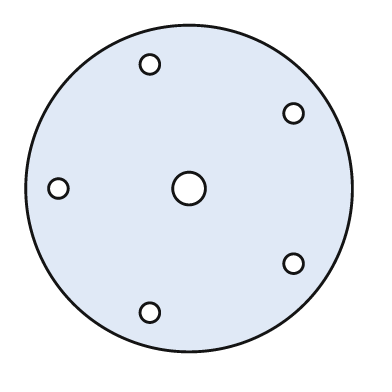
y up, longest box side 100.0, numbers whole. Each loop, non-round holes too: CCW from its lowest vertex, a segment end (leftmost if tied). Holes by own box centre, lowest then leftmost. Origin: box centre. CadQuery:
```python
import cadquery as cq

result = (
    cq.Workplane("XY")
    .moveTo(0.0, 0.0)
    .circle(50.0)
    .moveTo(-12.0, -38.0)
    .circle(3.0)
    .moveTo(32.0, -23.0)
    .circle(3.0)
    .moveTo(-40.0, 0.0)
    .circle(3.0)
    .moveTo(0.0, 0.0)
    .circle(5.0)
    .moveTo(32.0, 23.0)
    .circle(3.0)
    .moveTo(-12.0, 38.0)
    .circle(3.0)
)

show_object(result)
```